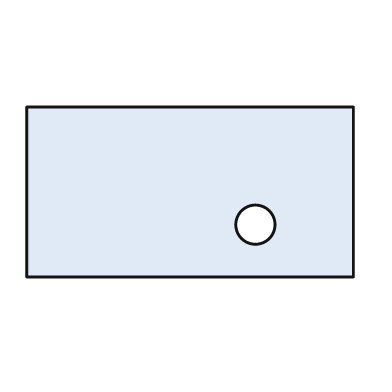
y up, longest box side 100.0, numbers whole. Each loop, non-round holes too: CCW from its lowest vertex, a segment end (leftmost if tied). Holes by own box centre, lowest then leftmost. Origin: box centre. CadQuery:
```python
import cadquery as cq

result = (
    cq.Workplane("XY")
    .moveTo(-50.0, -26.0)
    .lineTo(50.0, -26.0)
    .lineTo(50.0, 26.0)
    .lineTo(-50.0, 26.0)
    .close()
    .moveTo(20.0, -10.0)
    .circle(6.0)
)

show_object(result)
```